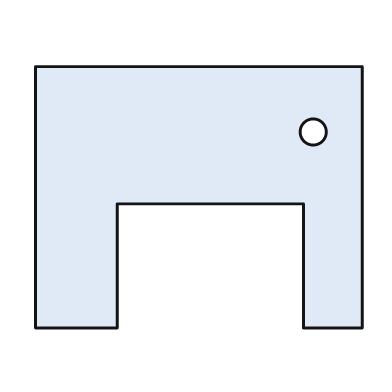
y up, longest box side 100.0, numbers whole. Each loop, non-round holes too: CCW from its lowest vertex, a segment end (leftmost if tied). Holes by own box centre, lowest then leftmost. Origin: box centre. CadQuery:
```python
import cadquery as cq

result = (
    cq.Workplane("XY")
    .moveTo(-50.0, -40.0)
    .lineTo(-25.0, -40.0)
    .lineTo(-25.0, -2.0)
    .lineTo(32.0, -2.0)
    .lineTo(32.0, -40.0)
    .lineTo(50.0, -40.0)
    .lineTo(50.0, 40.0)
    .lineTo(-50.0, 40.0)
    .close()
    .moveTo(35.0, 20.0)
    .circle(4.0)
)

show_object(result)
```